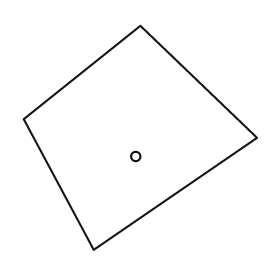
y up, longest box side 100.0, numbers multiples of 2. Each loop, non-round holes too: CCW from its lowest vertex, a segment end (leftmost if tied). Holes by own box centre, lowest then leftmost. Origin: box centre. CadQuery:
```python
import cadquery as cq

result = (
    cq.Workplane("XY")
    .moveTo(-20.0, -48.0)
    .lineTo(50.0, 0.0)
    .lineTo(0.0, 48.0)
    .lineTo(-50.0, 8.0)
    .close()
    .moveTo(-2.0, -8.0)
    .circle(2.0)
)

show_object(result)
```